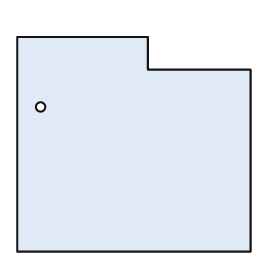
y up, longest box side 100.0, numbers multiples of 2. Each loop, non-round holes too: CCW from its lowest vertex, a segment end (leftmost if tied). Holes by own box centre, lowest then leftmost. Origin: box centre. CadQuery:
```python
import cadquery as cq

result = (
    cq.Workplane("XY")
    .moveTo(-50.0, -46.0)
    .lineTo(50.0, -46.0)
    .lineTo(50.0, 32.0)
    .lineTo(6.0, 32.0)
    .lineTo(6.0, 46.0)
    .lineTo(-50.0, 46.0)
    .close()
    .moveTo(-40.0, 16.0)
    .circle(2.0)
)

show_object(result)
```